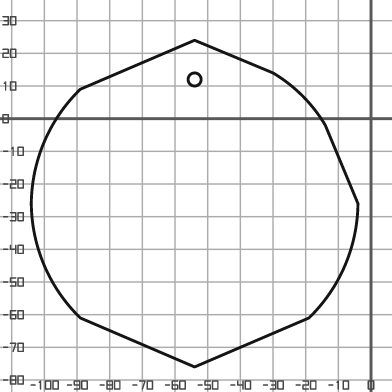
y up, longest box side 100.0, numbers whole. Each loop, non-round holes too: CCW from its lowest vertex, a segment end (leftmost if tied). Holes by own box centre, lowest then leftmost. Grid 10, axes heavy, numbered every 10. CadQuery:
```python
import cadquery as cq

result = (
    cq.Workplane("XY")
    .moveTo(-54.0, -76.0)
    .lineTo(-19.0, -61.0)
    .threePointArc((-8.0, -45.0), (-4.0, -26.0))
    .lineTo(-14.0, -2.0)
    .threePointArc((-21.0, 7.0), (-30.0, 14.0))
    .lineTo(-54.0, 24.0)
    .lineTo(-89.0, 9.0)
    .threePointArc((-100.0, -7.0), (-104.0, -26.0))
    .threePointArc((-100.0, -45.0), (-89.0, -61.0))
    .close()
    .moveTo(-54.0, 12.0)
    .circle(2.0)
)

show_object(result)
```